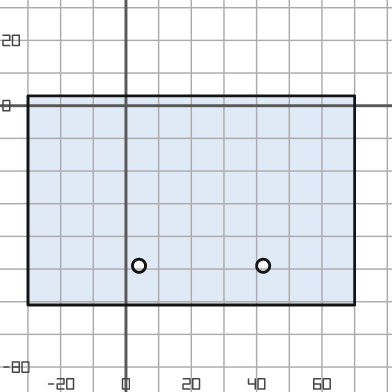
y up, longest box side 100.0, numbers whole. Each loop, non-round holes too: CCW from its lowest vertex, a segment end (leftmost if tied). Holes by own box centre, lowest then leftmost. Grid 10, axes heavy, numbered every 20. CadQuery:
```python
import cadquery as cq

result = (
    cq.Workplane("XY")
    .moveTo(-30.0, -61.0)
    .lineTo(70.0, -61.0)
    .lineTo(70.0, 3.0)
    .lineTo(-30.0, 3.0)
    .close()
    .moveTo(4.0, -49.0)
    .circle(2.0)
    .moveTo(42.0, -49.0)
    .circle(2.0)
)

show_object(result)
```